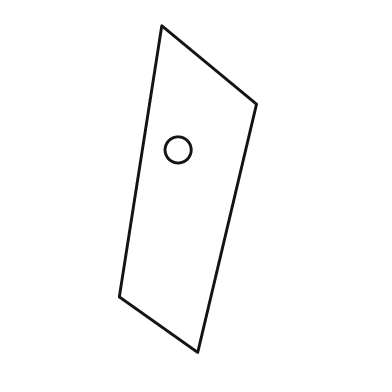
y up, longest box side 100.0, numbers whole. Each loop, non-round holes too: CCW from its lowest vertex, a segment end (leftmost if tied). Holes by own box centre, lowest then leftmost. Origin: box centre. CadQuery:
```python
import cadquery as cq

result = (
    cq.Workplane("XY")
    .moveTo(3.0, -50.0)
    .lineTo(21.0, 26.0)
    .lineTo(-8.0, 50.0)
    .lineTo(-21.0, -33.0)
    .close()
    .moveTo(-3.0, 12.0)
    .circle(4.0)
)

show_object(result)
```